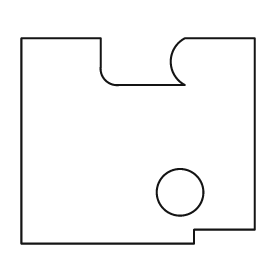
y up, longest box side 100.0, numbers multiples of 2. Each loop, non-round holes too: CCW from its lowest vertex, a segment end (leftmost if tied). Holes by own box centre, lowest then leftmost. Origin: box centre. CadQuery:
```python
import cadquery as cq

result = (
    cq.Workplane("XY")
    .moveTo(-50.0, -44.0)
    .lineTo(24.0, -44.0)
    .lineTo(24.0, -38.0)
    .lineTo(50.0, -38.0)
    .lineTo(50.0, 44.0)
    .lineTo(20.0, 44.0)
    .threePointArc((14.0, 34.0), (20.0, 24.0))
    .lineTo(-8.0, 24.0)
    .threePointArc((-14.0, 26.0), (-16.0, 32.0))
    .lineTo(-16.0, 44.0)
    .lineTo(-50.0, 44.0)
    .close()
    .moveTo(18.0, -22.0)
    .circle(10.0)
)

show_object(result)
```